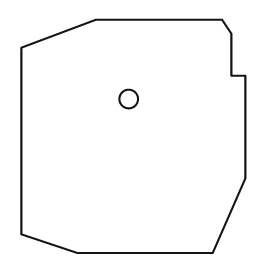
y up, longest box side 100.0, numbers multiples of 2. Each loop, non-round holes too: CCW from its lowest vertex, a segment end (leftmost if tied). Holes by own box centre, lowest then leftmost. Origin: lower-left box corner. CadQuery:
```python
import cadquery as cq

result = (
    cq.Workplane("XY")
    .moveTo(24.0, 0.0)
    .lineTo(82.0, 0.0)
    .lineTo(96.0, 32.0)
    .lineTo(96.0, 76.0)
    .lineTo(90.0, 76.0)
    .lineTo(90.0, 94.0)
    .lineTo(86.0, 100.0)
    .lineTo(32.0, 100.0)
    .lineTo(0.0, 88.0)
    .lineTo(0.0, 8.0)
    .close()
    .moveTo(46.0, 66.0)
    .circle(4.0)
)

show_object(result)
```